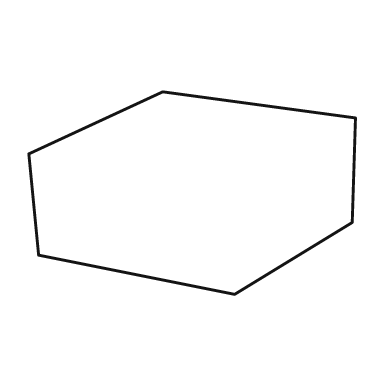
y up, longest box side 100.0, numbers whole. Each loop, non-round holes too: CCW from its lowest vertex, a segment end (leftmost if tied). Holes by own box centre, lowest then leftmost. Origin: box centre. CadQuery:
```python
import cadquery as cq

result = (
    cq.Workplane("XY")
    .moveTo(13.0, -31.0)
    .lineTo(49.0, -9.0)
    .lineTo(50.0, 23.0)
    .lineTo(-9.0, 31.0)
    .lineTo(-50.0, 12.0)
    .lineTo(-47.0, -19.0)
    .close()
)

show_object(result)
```